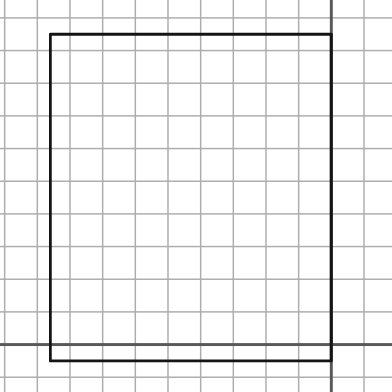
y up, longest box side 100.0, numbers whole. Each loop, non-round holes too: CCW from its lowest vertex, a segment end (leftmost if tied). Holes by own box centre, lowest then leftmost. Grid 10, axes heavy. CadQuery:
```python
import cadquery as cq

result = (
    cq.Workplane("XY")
    .moveTo(-86.0, -5.0)
    .lineTo(0.0, -5.0)
    .lineTo(0.0, 95.0)
    .lineTo(-86.0, 95.0)
    .close()
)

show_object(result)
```